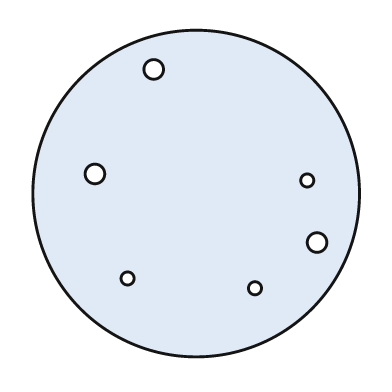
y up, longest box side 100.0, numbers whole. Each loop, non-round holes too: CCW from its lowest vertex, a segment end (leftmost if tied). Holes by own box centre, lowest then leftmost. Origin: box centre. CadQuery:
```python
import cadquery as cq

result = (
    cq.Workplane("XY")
    .moveTo(0.0, 0.0)
    .circle(50.0)
    .moveTo(18.0, -29.0)
    .circle(2.0)
    .moveTo(-21.0, -26.0)
    .circle(2.0)
    .moveTo(37.0, -15.0)
    .circle(3.0)
    .moveTo(34.0, 4.0)
    .circle(2.0)
    .moveTo(-31.0, 6.0)
    .circle(3.0)
    .moveTo(-13.0, 38.0)
    .circle(3.0)
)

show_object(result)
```